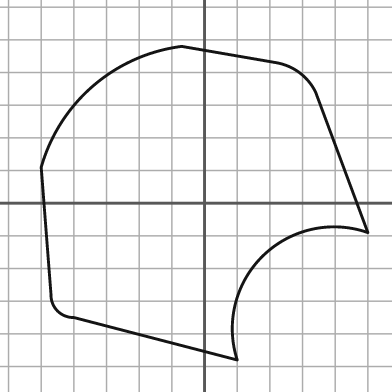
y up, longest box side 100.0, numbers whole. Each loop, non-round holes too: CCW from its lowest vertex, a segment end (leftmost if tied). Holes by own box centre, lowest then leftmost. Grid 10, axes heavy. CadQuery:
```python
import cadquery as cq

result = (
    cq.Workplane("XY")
    .moveTo(10.0, -48.0)
    .threePointArc((18.0, -16.0), (50.0, -9.0))
    .lineTo(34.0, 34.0)
    .threePointArc((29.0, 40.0), (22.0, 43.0))
    .lineTo(-7.0, 48.0)
    .threePointArc((-34.0, 36.0), (-50.0, 11.0))
    .lineTo(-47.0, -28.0)
    .threePointArc((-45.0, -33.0), (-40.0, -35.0))
    .close()
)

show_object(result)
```